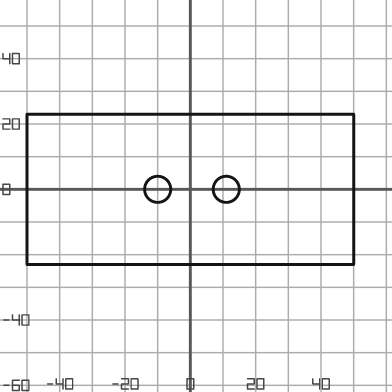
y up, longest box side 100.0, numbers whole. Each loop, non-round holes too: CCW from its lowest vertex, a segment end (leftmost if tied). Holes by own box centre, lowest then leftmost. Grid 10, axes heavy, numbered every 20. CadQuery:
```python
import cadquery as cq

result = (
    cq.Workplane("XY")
    .moveTo(-50.0, -23.0)
    .lineTo(50.0, -23.0)
    .lineTo(50.0, 23.0)
    .lineTo(-50.0, 23.0)
    .close()
    .moveTo(-10.0, 0.0)
    .circle(4.0)
    .moveTo(11.0, 0.0)
    .circle(4.0)
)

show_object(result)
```